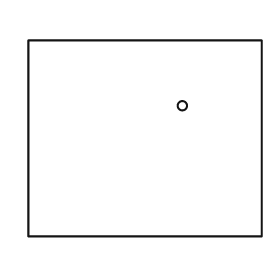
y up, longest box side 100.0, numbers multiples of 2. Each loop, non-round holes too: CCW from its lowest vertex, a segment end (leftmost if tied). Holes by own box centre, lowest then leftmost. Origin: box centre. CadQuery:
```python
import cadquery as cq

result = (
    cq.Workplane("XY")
    .moveTo(-50.0, -42.0)
    .lineTo(50.0, -42.0)
    .lineTo(50.0, 42.0)
    .lineTo(-50.0, 42.0)
    .close()
    .moveTo(16.0, 14.0)
    .circle(2.0)
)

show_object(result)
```